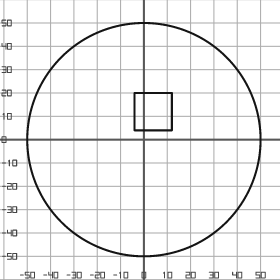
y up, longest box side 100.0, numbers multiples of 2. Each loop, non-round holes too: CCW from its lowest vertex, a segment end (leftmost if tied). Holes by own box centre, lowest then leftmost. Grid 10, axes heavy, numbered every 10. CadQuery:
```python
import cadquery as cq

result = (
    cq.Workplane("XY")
    .moveTo(0.0, 0.0)
    .circle(50.0)
    .moveTo(-4.0, 4.0)
    .lineTo(12.0, 4.0)
    .lineTo(12.0, 20.0)
    .lineTo(-4.0, 20.0)
    .close()
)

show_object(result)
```